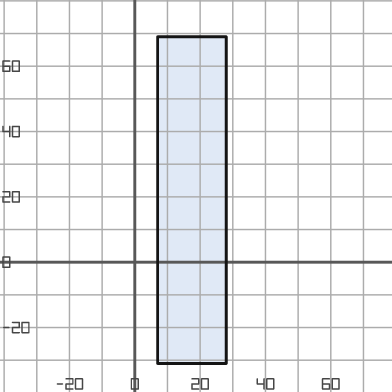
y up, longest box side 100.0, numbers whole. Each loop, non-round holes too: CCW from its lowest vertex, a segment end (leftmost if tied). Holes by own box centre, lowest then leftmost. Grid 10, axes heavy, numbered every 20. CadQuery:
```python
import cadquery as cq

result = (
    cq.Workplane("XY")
    .moveTo(7.0, -31.0)
    .lineTo(28.0, -31.0)
    .lineTo(28.0, 69.0)
    .lineTo(7.0, 69.0)
    .close()
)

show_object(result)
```